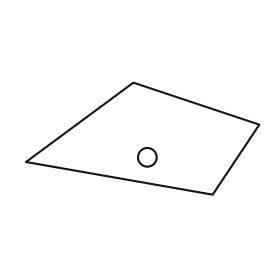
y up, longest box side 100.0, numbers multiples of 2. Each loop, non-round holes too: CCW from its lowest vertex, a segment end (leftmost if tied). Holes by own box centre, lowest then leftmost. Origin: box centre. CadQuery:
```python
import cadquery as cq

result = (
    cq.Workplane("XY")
    .moveTo(30.0, -24.0)
    .lineTo(50.0, 6.0)
    .lineTo(-4.0, 24.0)
    .lineTo(-50.0, -10.0)
    .close()
    .moveTo(2.0, -8.0)
    .circle(4.0)
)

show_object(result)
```